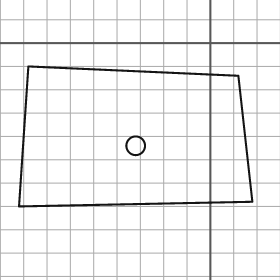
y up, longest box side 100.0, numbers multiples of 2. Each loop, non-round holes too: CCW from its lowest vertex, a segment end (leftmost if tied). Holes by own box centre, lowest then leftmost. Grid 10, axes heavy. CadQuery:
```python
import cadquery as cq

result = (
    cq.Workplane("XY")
    .moveTo(-82.0, -70.0)
    .lineTo(18.0, -68.0)
    .lineTo(12.0, -14.0)
    .lineTo(-78.0, -10.0)
    .close()
    .moveTo(-32.0, -44.0)
    .circle(4.0)
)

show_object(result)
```